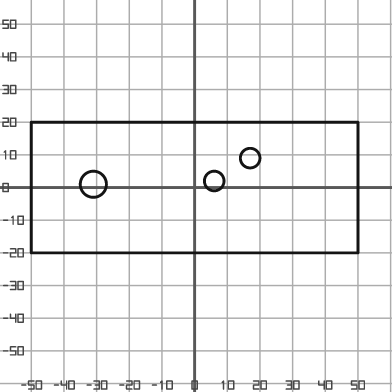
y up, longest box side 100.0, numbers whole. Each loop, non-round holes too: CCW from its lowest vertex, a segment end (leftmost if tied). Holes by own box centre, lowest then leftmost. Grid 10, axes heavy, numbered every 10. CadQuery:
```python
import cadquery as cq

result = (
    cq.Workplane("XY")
    .moveTo(-50.0, -20.0)
    .lineTo(50.0, -20.0)
    .lineTo(50.0, 20.0)
    .lineTo(-50.0, 20.0)
    .close()
    .moveTo(-31.0, 1.0)
    .circle(4.0)
    .moveTo(6.0, 2.0)
    .circle(3.0)
    .moveTo(17.0, 9.0)
    .circle(3.0)
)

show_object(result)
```